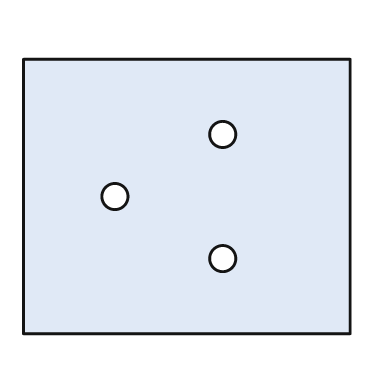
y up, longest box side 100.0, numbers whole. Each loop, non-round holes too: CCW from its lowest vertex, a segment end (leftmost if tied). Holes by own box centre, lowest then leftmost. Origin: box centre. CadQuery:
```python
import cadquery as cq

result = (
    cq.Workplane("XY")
    .moveTo(-50.0, -42.0)
    .lineTo(50.0, -42.0)
    .lineTo(50.0, 42.0)
    .lineTo(-50.0, 42.0)
    .close()
    .moveTo(11.0, -19.0)
    .circle(4.0)
    .moveTo(-22.0, 0.0)
    .circle(4.0)
    .moveTo(11.0, 19.0)
    .circle(4.0)
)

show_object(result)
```